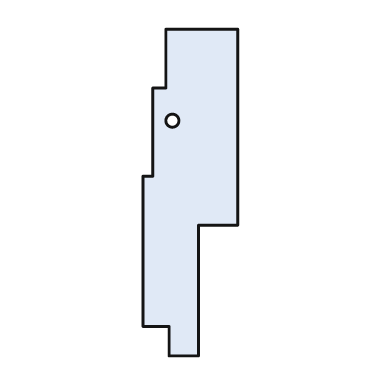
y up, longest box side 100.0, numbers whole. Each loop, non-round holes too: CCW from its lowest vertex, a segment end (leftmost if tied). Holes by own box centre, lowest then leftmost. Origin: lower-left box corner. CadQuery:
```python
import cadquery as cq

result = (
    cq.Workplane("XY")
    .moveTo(8.0, 0.0)
    .lineTo(17.0, 0.0)
    .lineTo(17.0, 40.0)
    .lineTo(29.0, 40.0)
    .lineTo(29.0, 100.0)
    .lineTo(7.0, 100.0)
    .lineTo(7.0, 82.0)
    .lineTo(3.0, 82.0)
    .lineTo(3.0, 55.0)
    .lineTo(0.0, 55.0)
    .lineTo(0.0, 9.0)
    .lineTo(8.0, 9.0)
    .close()
    .moveTo(9.0, 72.0)
    .circle(2.0)
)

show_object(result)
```